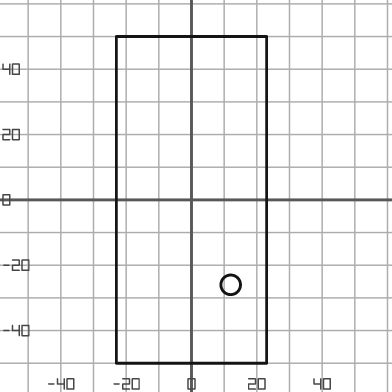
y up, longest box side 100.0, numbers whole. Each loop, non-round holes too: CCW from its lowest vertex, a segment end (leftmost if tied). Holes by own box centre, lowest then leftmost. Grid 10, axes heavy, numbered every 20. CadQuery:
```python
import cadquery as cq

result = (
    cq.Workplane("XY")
    .moveTo(-23.0, -50.0)
    .lineTo(23.0, -50.0)
    .lineTo(23.0, 50.0)
    .lineTo(-23.0, 50.0)
    .close()
    .moveTo(12.0, -26.0)
    .circle(3.0)
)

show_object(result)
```